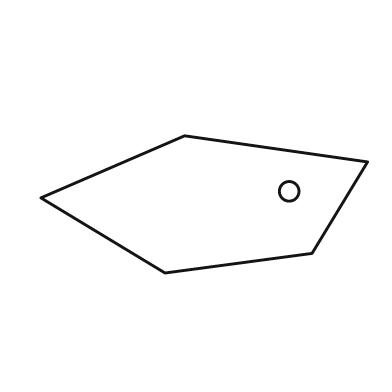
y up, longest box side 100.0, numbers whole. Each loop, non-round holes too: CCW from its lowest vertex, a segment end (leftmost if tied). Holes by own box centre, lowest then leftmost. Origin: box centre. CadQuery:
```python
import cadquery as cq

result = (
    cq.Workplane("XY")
    .moveTo(-12.0, -21.0)
    .lineTo(33.0, -15.0)
    .lineTo(50.0, 13.0)
    .lineTo(-6.0, 21.0)
    .lineTo(-50.0, 2.0)
    .close()
    .moveTo(26.0, 4.0)
    .circle(3.0)
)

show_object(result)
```